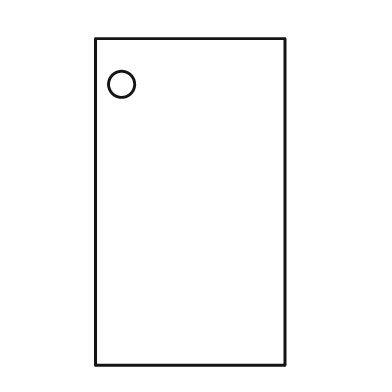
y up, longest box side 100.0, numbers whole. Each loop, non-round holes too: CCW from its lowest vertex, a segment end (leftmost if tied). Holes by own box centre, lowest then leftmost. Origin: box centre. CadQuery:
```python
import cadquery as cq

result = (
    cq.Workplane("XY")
    .moveTo(-29.0, -50.0)
    .lineTo(29.0, -50.0)
    .lineTo(29.0, 50.0)
    .lineTo(-29.0, 50.0)
    .close()
    .moveTo(-21.0, 36.0)
    .circle(4.0)
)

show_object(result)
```